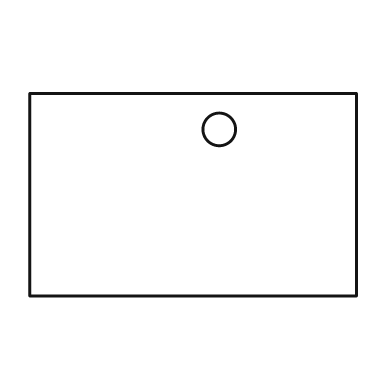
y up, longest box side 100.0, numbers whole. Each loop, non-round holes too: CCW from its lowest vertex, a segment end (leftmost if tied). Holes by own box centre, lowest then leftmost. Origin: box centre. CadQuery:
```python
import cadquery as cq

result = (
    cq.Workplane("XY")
    .moveTo(-50.0, -31.0)
    .lineTo(50.0, -31.0)
    .lineTo(50.0, 31.0)
    .lineTo(-50.0, 31.0)
    .close()
    .moveTo(8.0, 20.0)
    .circle(5.0)
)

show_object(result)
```